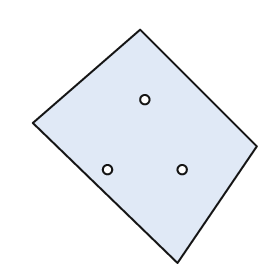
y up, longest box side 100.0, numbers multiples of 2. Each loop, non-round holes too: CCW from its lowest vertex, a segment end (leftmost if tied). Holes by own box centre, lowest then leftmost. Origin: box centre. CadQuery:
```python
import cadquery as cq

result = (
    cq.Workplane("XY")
    .moveTo(14.0, -50.0)
    .lineTo(48.0, 0.0)
    .lineTo(-2.0, 50.0)
    .lineTo(-48.0, 10.0)
    .close()
    .moveTo(-16.0, -10.0)
    .circle(2.0)
    .moveTo(16.0, -10.0)
    .circle(2.0)
    .moveTo(0.0, 20.0)
    .circle(2.0)
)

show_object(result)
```